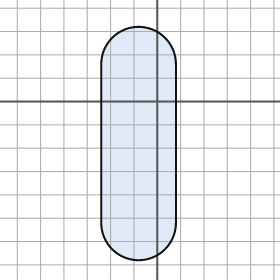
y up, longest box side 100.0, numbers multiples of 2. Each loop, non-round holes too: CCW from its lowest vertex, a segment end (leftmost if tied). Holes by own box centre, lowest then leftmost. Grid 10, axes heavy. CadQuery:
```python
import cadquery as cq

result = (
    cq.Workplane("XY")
    .moveTo(-24.0, -52.0)
    .threePointArc((-8.0, -68.0), (8.0, -52.0))
    .lineTo(8.0, 16.0)
    .threePointArc((-8.0, 32.0), (-24.0, 16.0))
    .close()
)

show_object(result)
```